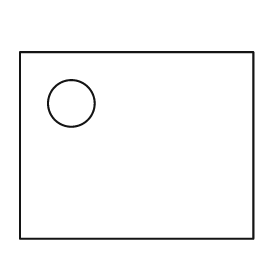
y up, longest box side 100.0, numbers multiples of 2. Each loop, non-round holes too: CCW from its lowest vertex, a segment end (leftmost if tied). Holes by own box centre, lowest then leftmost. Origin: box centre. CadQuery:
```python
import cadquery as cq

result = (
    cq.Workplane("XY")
    .moveTo(-50.0, -40.0)
    .lineTo(50.0, -40.0)
    .lineTo(50.0, 40.0)
    .lineTo(-50.0, 40.0)
    .close()
    .moveTo(-28.0, 18.0)
    .circle(10.0)
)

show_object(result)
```